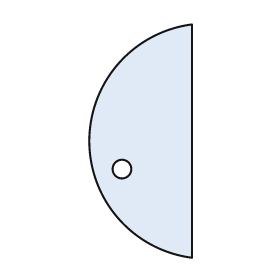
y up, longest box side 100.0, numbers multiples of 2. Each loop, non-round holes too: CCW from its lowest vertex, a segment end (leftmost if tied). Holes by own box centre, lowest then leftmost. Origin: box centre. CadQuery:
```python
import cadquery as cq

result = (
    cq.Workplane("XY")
    .moveTo(22.0, -50.0)
    .lineTo(22.0, 50.0)
    .threePointArc((-22.0, 0.0), (22.0, -50.0))
    .close()
    .moveTo(-8.0, -12.0)
    .circle(4.0)
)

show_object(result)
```